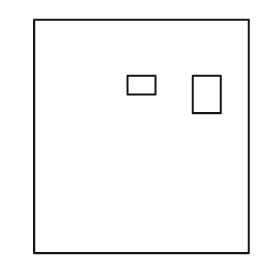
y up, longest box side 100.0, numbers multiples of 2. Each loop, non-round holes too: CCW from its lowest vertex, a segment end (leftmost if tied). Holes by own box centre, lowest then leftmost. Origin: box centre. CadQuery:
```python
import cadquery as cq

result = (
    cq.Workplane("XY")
    .moveTo(-46.0, -50.0)
    .lineTo(46.0, -50.0)
    .lineTo(46.0, 50.0)
    .lineTo(-46.0, 50.0)
    .close()
    .moveTo(22.0, 10.0)
    .lineTo(34.0, 10.0)
    .lineTo(34.0, 26.0)
    .lineTo(22.0, 26.0)
    .close()
    .moveTo(-6.0, 18.0)
    .lineTo(6.0, 18.0)
    .lineTo(6.0, 26.0)
    .lineTo(-6.0, 26.0)
    .close()
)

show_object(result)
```